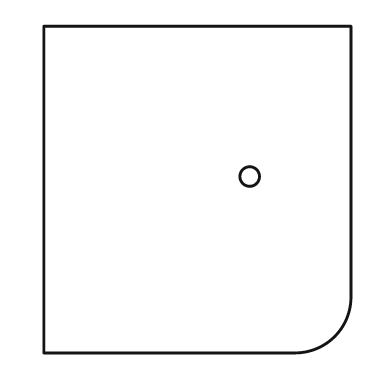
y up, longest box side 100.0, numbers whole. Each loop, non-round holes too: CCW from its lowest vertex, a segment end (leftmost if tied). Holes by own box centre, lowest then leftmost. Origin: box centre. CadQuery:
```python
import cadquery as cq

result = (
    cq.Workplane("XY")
    .moveTo(-47.0, -50.0)
    .lineTo(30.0, -50.0)
    .threePointArc((42.0, -45.0), (47.0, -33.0))
    .lineTo(47.0, 50.0)
    .lineTo(-47.0, 50.0)
    .close()
    .moveTo(16.0, 4.0)
    .circle(3.0)
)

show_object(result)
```